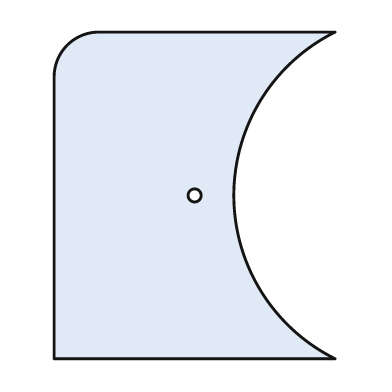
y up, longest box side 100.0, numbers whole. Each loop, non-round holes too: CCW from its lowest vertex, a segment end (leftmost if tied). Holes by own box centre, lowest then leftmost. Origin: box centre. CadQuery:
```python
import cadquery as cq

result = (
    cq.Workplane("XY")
    .moveTo(-43.0, -50.0)
    .lineTo(43.0, -50.0)
    .threePointArc((12.0, 0.0), (43.0, 50.0))
    .lineTo(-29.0, 50.0)
    .threePointArc((-39.0, 46.0), (-43.0, 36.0))
    .close()
    .moveTo(0.0, 0.0)
    .circle(2.0)
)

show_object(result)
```